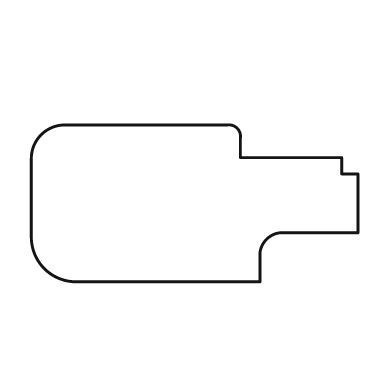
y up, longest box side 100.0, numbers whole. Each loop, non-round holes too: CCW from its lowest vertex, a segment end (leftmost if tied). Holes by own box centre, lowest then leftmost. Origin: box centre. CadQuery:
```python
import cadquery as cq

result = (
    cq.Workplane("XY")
    .moveTo(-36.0, -24.0)
    .lineTo(20.0, -24.0)
    .lineTo(20.0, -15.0)
    .threePointArc((22.0, -11.0), (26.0, -9.0))
    .lineTo(50.0, -9.0)
    .lineTo(50.0, 9.0)
    .lineTo(45.0, 9.0)
    .lineTo(45.0, 14.0)
    .lineTo(14.0, 14.0)
    .lineTo(14.0, 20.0)
    .threePointArc((13.0, 23.0), (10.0, 24.0))
    .lineTo(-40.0, 24.0)
    .threePointArc((-47.0, 21.0), (-50.0, 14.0))
    .lineTo(-50.0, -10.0)
    .threePointArc((-46.0, -20.0), (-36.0, -24.0))
    .close()
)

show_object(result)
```